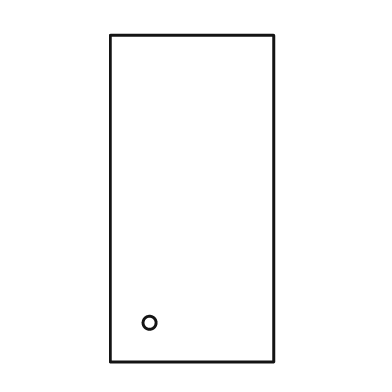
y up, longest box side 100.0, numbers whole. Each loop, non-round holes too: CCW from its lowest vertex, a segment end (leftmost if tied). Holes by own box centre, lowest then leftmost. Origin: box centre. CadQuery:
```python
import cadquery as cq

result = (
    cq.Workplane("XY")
    .moveTo(-25.0, -50.0)
    .lineTo(25.0, -50.0)
    .lineTo(25.0, 50.0)
    .lineTo(-25.0, 50.0)
    .close()
    .moveTo(-13.0, -38.0)
    .circle(2.0)
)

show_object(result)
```